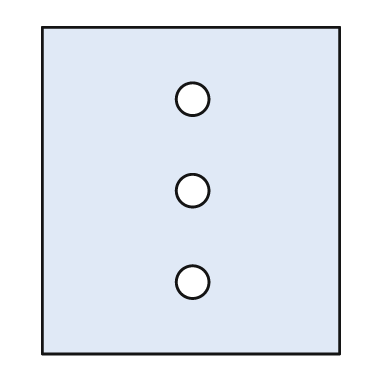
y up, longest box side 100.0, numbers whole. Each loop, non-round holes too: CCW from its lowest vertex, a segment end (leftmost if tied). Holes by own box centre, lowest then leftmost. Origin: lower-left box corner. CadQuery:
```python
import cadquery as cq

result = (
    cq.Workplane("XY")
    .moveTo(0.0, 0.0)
    .lineTo(91.0, 0.0)
    .lineTo(91.0, 100.0)
    .lineTo(0.0, 100.0)
    .close()
    .moveTo(46.0, 22.0)
    .circle(5.0)
    .moveTo(46.0, 50.0)
    .circle(5.0)
    .moveTo(46.0, 78.0)
    .circle(5.0)
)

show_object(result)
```